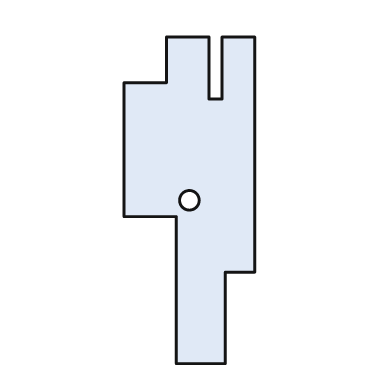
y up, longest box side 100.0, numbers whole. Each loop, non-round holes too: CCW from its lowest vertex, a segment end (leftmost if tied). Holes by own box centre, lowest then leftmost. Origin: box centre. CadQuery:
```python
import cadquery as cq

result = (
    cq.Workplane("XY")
    .moveTo(-4.0, -50.0)
    .lineTo(11.0, -50.0)
    .lineTo(11.0, -22.0)
    .lineTo(20.0, -22.0)
    .lineTo(20.0, 50.0)
    .lineTo(10.0, 50.0)
    .lineTo(10.0, 31.0)
    .lineTo(6.0, 31.0)
    .lineTo(6.0, 50.0)
    .lineTo(-7.0, 50.0)
    .lineTo(-7.0, 36.0)
    .lineTo(-20.0, 36.0)
    .lineTo(-20.0, -5.0)
    .lineTo(-4.0, -5.0)
    .close()
    .moveTo(0.0, 0.0)
    .circle(3.0)
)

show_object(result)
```